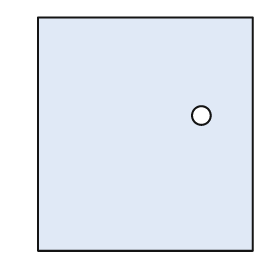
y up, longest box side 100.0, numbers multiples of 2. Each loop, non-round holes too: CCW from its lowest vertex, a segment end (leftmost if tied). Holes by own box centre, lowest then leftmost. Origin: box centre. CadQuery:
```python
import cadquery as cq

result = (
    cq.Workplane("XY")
    .moveTo(-46.0, -50.0)
    .lineTo(46.0, -50.0)
    .lineTo(46.0, 50.0)
    .lineTo(-46.0, 50.0)
    .close()
    .moveTo(24.0, 8.0)
    .circle(4.0)
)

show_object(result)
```